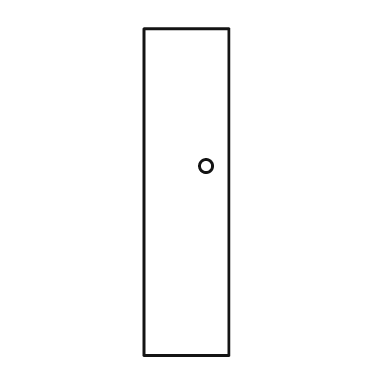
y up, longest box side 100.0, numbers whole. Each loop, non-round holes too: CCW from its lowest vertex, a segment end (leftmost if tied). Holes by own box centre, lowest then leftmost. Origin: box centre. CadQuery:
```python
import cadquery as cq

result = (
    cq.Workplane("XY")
    .moveTo(-13.0, -50.0)
    .lineTo(13.0, -50.0)
    .lineTo(13.0, 50.0)
    .lineTo(-13.0, 50.0)
    .close()
    .moveTo(6.0, 8.0)
    .circle(2.0)
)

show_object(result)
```